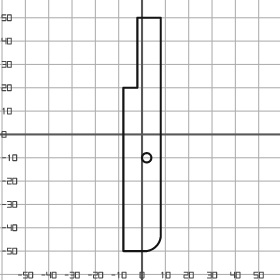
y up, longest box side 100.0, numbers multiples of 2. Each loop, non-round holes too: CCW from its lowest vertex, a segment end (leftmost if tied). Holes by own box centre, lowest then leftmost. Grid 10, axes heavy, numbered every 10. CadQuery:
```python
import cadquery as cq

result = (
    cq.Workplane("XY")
    .moveTo(-8.0, -50.0)
    .lineTo(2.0, -50.0)
    .threePointArc((6.0, -48.0), (8.0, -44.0))
    .lineTo(8.0, 50.0)
    .lineTo(-2.0, 50.0)
    .lineTo(-2.0, 20.0)
    .lineTo(-8.0, 20.0)
    .close()
    .moveTo(2.0, -10.0)
    .circle(2.0)
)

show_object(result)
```